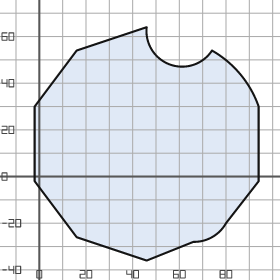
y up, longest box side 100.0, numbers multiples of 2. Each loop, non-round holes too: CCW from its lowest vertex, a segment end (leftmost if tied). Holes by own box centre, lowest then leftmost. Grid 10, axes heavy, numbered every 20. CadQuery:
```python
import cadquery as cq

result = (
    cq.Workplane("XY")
    .moveTo(46.0, -36.0)
    .lineTo(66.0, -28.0)
    .threePointArc((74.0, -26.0), (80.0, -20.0))
    .lineTo(94.0, -2.0)
    .lineTo(94.0, 30.0)
    .threePointArc((86.0, 44.0), (74.0, 54.0))
    .threePointArc((56.0, 48.0), (46.0, 64.0))
    .lineTo(16.0, 54.0)
    .lineTo(-2.0, 30.0)
    .lineTo(-2.0, -2.0)
    .lineTo(16.0, -26.0)
    .close()
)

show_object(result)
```